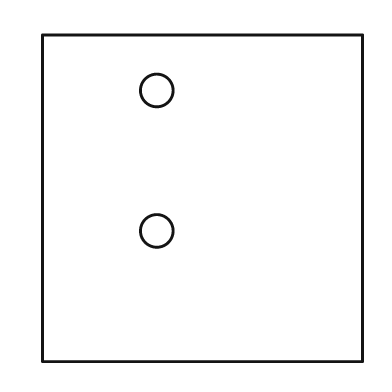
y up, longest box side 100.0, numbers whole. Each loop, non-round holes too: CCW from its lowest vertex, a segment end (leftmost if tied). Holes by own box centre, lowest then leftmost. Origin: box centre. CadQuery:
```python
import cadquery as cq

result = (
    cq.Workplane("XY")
    .moveTo(-49.0, -50.0)
    .lineTo(49.0, -50.0)
    .lineTo(49.0, 50.0)
    .lineTo(-49.0, 50.0)
    .close()
    .moveTo(-14.0, -10.0)
    .circle(5.0)
    .moveTo(-14.0, 33.0)
    .circle(5.0)
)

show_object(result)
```